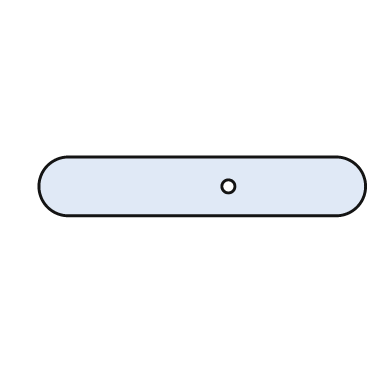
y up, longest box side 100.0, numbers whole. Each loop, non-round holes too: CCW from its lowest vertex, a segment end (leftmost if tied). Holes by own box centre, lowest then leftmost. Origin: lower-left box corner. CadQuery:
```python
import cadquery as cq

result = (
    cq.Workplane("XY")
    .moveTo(9.0, 0.0)
    .lineTo(91.0, 0.0)
    .threePointArc((100.0, 9.0), (91.0, 18.0))
    .lineTo(9.0, 18.0)
    .threePointArc((0.0, 9.0), (9.0, 0.0))
    .close()
    .moveTo(58.0, 9.0)
    .circle(2.0)
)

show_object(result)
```